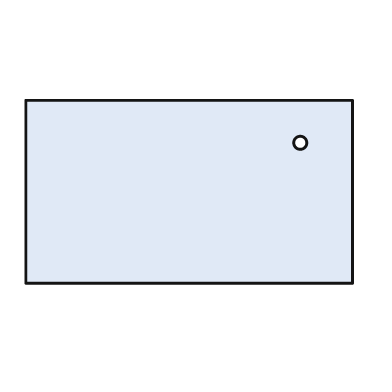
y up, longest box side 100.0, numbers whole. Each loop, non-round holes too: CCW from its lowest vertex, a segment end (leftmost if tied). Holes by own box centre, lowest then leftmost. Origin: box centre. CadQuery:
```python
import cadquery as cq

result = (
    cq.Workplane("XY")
    .moveTo(-50.0, -28.0)
    .lineTo(50.0, -28.0)
    .lineTo(50.0, 28.0)
    .lineTo(-50.0, 28.0)
    .close()
    .moveTo(34.0, 15.0)
    .circle(2.0)
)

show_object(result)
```